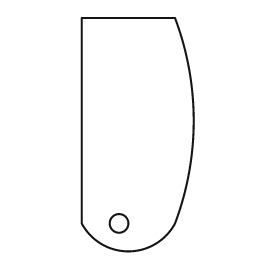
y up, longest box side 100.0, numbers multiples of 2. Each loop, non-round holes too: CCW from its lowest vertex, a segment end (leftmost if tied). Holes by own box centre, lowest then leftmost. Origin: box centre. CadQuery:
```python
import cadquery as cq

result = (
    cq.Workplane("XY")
    .moveTo(-24.0, -38.0)
    .threePointArc((-4.0, -50.0), (16.0, -38.0))
    .threePointArc((24.0, 6.0), (16.0, 50.0))
    .lineTo(-24.0, 50.0)
    .close()
    .moveTo(-8.0, -38.0)
    .circle(4.0)
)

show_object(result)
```